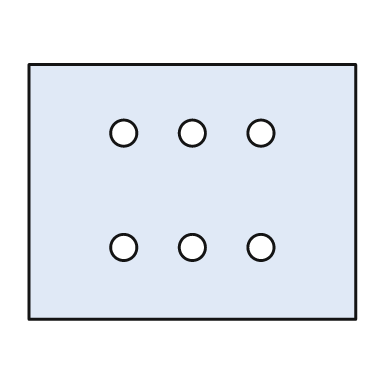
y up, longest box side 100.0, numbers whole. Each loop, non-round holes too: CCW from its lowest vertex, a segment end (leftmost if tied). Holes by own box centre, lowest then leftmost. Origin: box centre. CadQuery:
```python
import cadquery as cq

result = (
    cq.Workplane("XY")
    .moveTo(-50.0, -39.0)
    .lineTo(50.0, -39.0)
    .lineTo(50.0, 39.0)
    .lineTo(-50.0, 39.0)
    .close()
    .moveTo(-21.0, -17.0)
    .circle(4.0)
    .moveTo(0.0, -17.0)
    .circle(4.0)
    .moveTo(21.0, -17.0)
    .circle(4.0)
    .moveTo(-21.0, 18.0)
    .circle(4.0)
    .moveTo(0.0, 18.0)
    .circle(4.0)
    .moveTo(21.0, 18.0)
    .circle(4.0)
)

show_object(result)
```